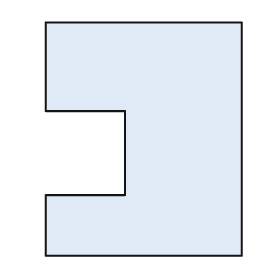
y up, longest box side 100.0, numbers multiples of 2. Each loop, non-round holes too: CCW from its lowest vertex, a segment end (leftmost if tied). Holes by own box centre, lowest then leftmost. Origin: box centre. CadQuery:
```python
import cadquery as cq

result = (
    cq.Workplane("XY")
    .moveTo(-42.0, -50.0)
    .lineTo(42.0, -50.0)
    .lineTo(42.0, 50.0)
    .lineTo(-42.0, 50.0)
    .lineTo(-42.0, 12.0)
    .lineTo(-8.0, 12.0)
    .lineTo(-8.0, -24.0)
    .lineTo(-42.0, -24.0)
    .close()
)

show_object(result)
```